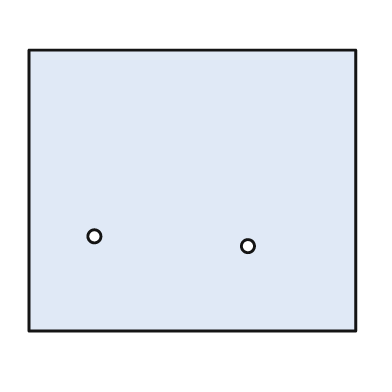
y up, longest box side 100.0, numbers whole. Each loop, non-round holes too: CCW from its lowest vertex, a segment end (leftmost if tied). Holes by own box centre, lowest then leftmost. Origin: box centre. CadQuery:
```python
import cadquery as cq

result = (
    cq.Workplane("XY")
    .moveTo(-50.0, -43.0)
    .lineTo(50.0, -43.0)
    .lineTo(50.0, 43.0)
    .lineTo(-50.0, 43.0)
    .close()
    .moveTo(17.0, -17.0)
    .circle(2.0)
    .moveTo(-30.0, -14.0)
    .circle(2.0)
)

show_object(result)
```